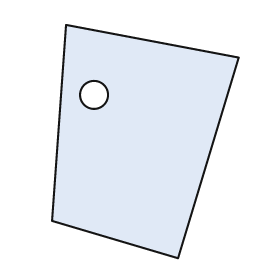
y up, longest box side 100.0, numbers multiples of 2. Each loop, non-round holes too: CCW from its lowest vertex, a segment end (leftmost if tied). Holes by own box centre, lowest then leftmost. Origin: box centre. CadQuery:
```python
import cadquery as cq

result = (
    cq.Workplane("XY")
    .moveTo(14.0, -50.0)
    .lineTo(40.0, 36.0)
    .lineTo(-34.0, 50.0)
    .lineTo(-40.0, -34.0)
    .close()
    .moveTo(-22.0, 20.0)
    .circle(6.0)
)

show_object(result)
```